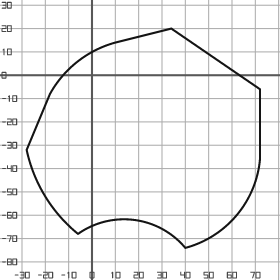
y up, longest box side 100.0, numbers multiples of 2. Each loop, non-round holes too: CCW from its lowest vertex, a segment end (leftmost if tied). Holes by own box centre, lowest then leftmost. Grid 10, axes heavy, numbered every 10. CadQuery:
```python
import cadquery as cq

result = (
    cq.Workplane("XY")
    .moveTo(40.0, -74.0)
    .threePointArc((62.0, -60.0), (72.0, -36.0))
    .lineTo(72.0, -6.0)
    .lineTo(34.0, 20.0)
    .lineTo(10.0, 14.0)
    .threePointArc((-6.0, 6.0), (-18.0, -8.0))
    .lineTo(-28.0, -32.0)
    .threePointArc((-20.0, -52.0), (-6.0, -68.0))
    .threePointArc((18.0, -62.0), (40.0, -74.0))
    .close()
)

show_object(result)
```